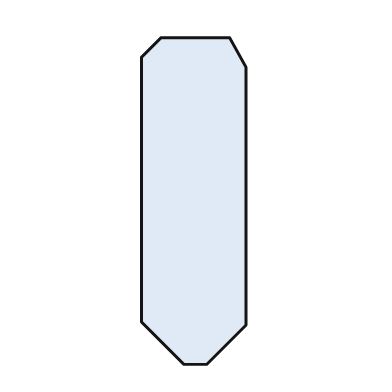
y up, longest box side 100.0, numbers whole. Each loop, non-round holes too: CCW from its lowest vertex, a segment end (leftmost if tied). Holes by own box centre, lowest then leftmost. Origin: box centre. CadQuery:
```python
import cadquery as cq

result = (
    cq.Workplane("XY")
    .moveTo(-3.0, -50.0)
    .lineTo(4.0, -50.0)
    .lineTo(16.0, -38.0)
    .lineTo(16.0, 41.0)
    .lineTo(11.0, 50.0)
    .lineTo(-10.0, 50.0)
    .lineTo(-16.0, 44.0)
    .lineTo(-16.0, -37.0)
    .close()
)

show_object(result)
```